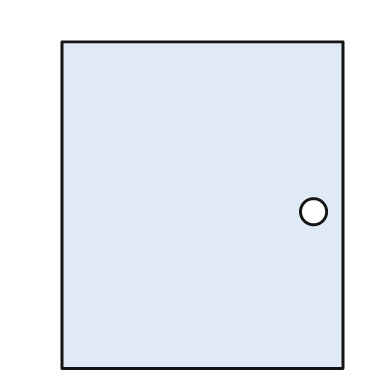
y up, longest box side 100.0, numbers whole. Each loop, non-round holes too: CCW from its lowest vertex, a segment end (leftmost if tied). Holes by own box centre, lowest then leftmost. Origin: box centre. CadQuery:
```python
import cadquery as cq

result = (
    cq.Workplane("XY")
    .moveTo(-43.0, -50.0)
    .lineTo(43.0, -50.0)
    .lineTo(43.0, 50.0)
    .lineTo(-43.0, 50.0)
    .close()
    .moveTo(34.0, -2.0)
    .circle(4.0)
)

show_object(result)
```